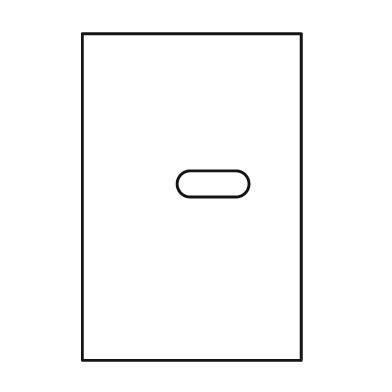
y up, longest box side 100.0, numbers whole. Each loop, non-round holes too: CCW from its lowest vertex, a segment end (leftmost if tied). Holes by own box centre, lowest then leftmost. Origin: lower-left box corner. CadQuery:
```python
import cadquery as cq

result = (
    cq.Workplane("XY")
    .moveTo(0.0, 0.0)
    .lineTo(67.0, 0.0)
    .lineTo(67.0, 100.0)
    .lineTo(0.0, 100.0)
    .close()
    .moveTo(33.0, 50.0)
    .lineTo(47.0, 50.0)
    .threePointArc((51.0, 54.0), (47.0, 58.0))
    .lineTo(33.0, 58.0)
    .threePointArc((29.0, 54.0), (33.0, 50.0))
    .close()
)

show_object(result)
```